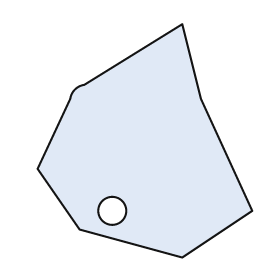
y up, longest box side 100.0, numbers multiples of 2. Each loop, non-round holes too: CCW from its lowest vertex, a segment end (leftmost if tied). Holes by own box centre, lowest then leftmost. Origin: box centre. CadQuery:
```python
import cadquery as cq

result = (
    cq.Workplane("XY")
    .moveTo(16.0, -50.0)
    .lineTo(46.0, -30.0)
    .lineTo(24.0, 18.0)
    .lineTo(16.0, 50.0)
    .lineTo(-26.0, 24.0)
    .threePointArc((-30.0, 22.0), (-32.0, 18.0))
    .lineTo(-46.0, -12.0)
    .lineTo(-28.0, -38.0)
    .close()
    .moveTo(-14.0, -30.0)
    .circle(6.0)
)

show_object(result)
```